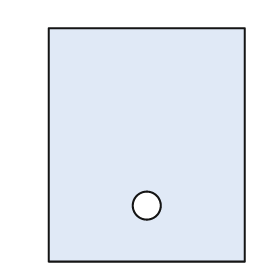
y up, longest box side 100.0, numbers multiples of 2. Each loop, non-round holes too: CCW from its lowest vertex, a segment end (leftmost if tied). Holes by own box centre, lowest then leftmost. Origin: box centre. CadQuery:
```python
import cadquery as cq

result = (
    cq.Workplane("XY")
    .moveTo(-42.0, -50.0)
    .lineTo(42.0, -50.0)
    .lineTo(42.0, 50.0)
    .lineTo(-42.0, 50.0)
    .close()
    .moveTo(0.0, -26.0)
    .circle(6.0)
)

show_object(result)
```